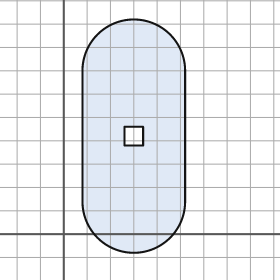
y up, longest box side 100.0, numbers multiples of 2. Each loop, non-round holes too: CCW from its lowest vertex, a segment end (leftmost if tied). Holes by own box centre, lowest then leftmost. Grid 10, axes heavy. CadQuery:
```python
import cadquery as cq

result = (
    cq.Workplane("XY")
    .moveTo(8.0, 14.0)
    .threePointArc((30.0, -8.0), (52.0, 14.0))
    .lineTo(52.0, 70.0)
    .threePointArc((30.0, 92.0), (8.0, 70.0))
    .close()
    .moveTo(26.0, 38.0)
    .lineTo(34.0, 38.0)
    .lineTo(34.0, 46.0)
    .lineTo(26.0, 46.0)
    .close()
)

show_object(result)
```